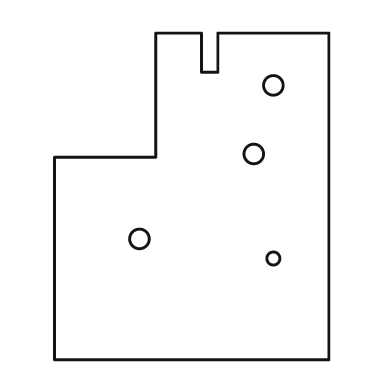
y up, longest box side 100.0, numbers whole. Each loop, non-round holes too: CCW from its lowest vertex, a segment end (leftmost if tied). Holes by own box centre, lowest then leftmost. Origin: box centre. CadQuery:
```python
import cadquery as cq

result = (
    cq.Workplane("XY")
    .moveTo(-42.0, -50.0)
    .lineTo(42.0, -50.0)
    .lineTo(42.0, 50.0)
    .lineTo(8.0, 50.0)
    .lineTo(8.0, 38.0)
    .lineTo(3.0, 38.0)
    .lineTo(3.0, 50.0)
    .lineTo(-11.0, 50.0)
    .lineTo(-11.0, 12.0)
    .lineTo(-42.0, 12.0)
    .close()
    .moveTo(25.0, -19.0)
    .circle(2.0)
    .moveTo(-16.0, -13.0)
    .circle(3.0)
    .moveTo(19.0, 13.0)
    .circle(3.0)
    .moveTo(25.0, 34.0)
    .circle(3.0)
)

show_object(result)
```